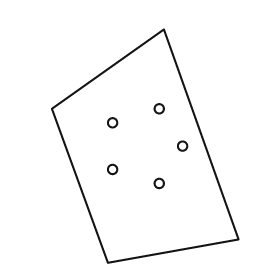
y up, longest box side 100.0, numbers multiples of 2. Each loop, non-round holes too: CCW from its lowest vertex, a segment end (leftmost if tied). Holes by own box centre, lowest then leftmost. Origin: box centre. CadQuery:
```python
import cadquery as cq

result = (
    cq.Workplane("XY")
    .moveTo(-16.0, -50.0)
    .lineTo(40.0, -40.0)
    .lineTo(8.0, 50.0)
    .lineTo(-40.0, 16.0)
    .close()
    .moveTo(6.0, -16.0)
    .circle(2.0)
    .moveTo(-14.0, -10.0)
    .circle(2.0)
    .moveTo(16.0, 0.0)
    .circle(2.0)
    .moveTo(-14.0, 10.0)
    .circle(2.0)
    .moveTo(6.0, 16.0)
    .circle(2.0)
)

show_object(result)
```